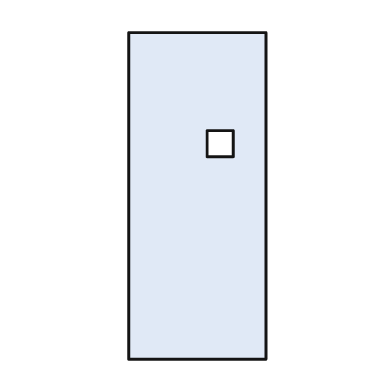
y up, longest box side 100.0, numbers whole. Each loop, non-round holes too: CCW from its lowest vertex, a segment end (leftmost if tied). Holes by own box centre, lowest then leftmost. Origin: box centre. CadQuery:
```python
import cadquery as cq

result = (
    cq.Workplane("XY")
    .moveTo(-21.0, -50.0)
    .lineTo(21.0, -50.0)
    .lineTo(21.0, 50.0)
    .lineTo(-21.0, 50.0)
    .close()
    .moveTo(3.0, 12.0)
    .lineTo(11.0, 12.0)
    .lineTo(11.0, 20.0)
    .lineTo(3.0, 20.0)
    .close()
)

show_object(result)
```